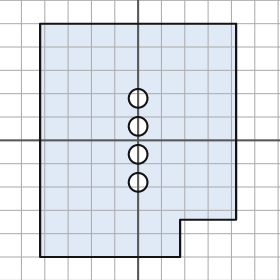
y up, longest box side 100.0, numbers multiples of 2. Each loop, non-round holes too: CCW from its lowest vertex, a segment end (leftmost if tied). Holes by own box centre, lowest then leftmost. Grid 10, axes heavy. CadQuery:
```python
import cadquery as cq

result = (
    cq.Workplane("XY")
    .moveTo(-42.0, -50.0)
    .lineTo(18.0, -50.0)
    .lineTo(18.0, -34.0)
    .lineTo(42.0, -34.0)
    .lineTo(42.0, 50.0)
    .lineTo(-42.0, 50.0)
    .close()
    .moveTo(0.0, -18.0)
    .circle(4.0)
    .moveTo(0.0, -6.0)
    .circle(4.0)
    .moveTo(0.0, 6.0)
    .circle(4.0)
    .moveTo(0.0, 18.0)
    .circle(4.0)
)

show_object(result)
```